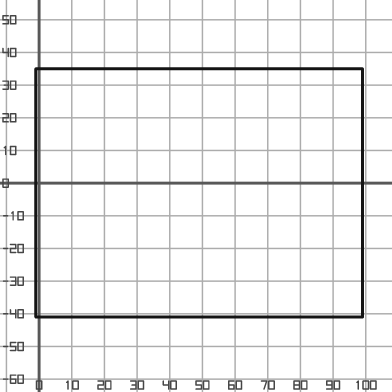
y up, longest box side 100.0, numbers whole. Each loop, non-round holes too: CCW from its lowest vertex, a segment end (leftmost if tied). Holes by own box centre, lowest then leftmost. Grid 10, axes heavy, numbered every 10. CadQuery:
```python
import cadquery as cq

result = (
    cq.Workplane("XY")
    .moveTo(-1.0, -41.0)
    .lineTo(99.0, -41.0)
    .lineTo(99.0, 35.0)
    .lineTo(-1.0, 35.0)
    .close()
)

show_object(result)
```